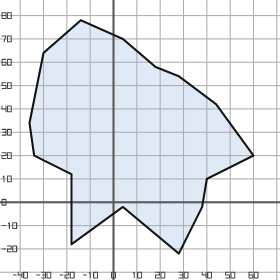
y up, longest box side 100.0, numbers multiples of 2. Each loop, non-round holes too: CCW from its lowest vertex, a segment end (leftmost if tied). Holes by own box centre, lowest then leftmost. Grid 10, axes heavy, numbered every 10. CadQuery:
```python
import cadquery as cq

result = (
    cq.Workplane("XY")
    .moveTo(28.0, -22.0)
    .lineTo(38.0, -2.0)
    .lineTo(40.0, 10.0)
    .lineTo(60.0, 20.0)
    .lineTo(44.0, 42.0)
    .lineTo(28.0, 54.0)
    .lineTo(18.0, 58.0)
    .lineTo(4.0, 70.0)
    .lineTo(-14.0, 78.0)
    .lineTo(-30.0, 64.0)
    .lineTo(-36.0, 34.0)
    .lineTo(-34.0, 20.0)
    .lineTo(-18.0, 12.0)
    .lineTo(-18.0, -18.0)
    .lineTo(4.0, -2.0)
    .close()
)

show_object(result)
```